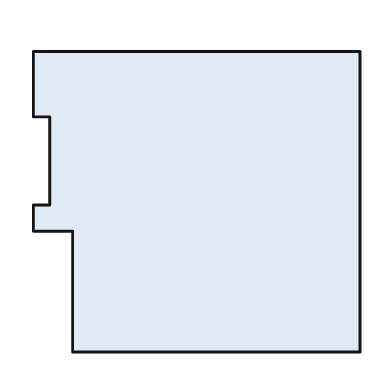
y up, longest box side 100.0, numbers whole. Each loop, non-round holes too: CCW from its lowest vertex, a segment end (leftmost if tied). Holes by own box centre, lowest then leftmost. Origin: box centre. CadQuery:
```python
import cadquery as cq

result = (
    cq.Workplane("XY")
    .moveTo(-38.0, -46.0)
    .lineTo(50.0, -46.0)
    .lineTo(50.0, 46.0)
    .lineTo(-50.0, 46.0)
    .lineTo(-50.0, 26.0)
    .lineTo(-45.0, 26.0)
    .lineTo(-45.0, -1.0)
    .lineTo(-50.0, -1.0)
    .lineTo(-50.0, -9.0)
    .lineTo(-38.0, -9.0)
    .close()
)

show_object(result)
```